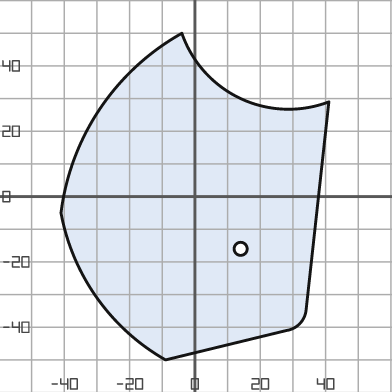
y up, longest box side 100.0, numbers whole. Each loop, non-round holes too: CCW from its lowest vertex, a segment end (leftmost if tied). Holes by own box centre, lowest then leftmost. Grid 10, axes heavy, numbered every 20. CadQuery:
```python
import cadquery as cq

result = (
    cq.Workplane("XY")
    .moveTo(-9.0, -50.0)
    .lineTo(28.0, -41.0)
    .threePointArc((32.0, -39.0), (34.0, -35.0))
    .lineTo(41.0, 29.0)
    .threePointArc((14.0, 30.0), (-4.0, 50.0))
    .threePointArc((-29.0, 27.0), (-41.0, -5.0))
    .threePointArc((-30.0, -31.0), (-9.0, -50.0))
    .close()
    .moveTo(14.0, -16.0)
    .circle(2.0)
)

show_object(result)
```